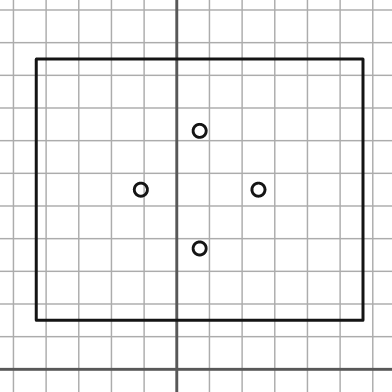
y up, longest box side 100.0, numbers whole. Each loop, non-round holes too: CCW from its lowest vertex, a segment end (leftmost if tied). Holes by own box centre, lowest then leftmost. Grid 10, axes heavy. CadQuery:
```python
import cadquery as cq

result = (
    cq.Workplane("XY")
    .moveTo(-43.0, 15.0)
    .lineTo(57.0, 15.0)
    .lineTo(57.0, 95.0)
    .lineTo(-43.0, 95.0)
    .close()
    .moveTo(7.0, 37.0)
    .circle(2.0)
    .moveTo(-11.0, 55.0)
    .circle(2.0)
    .moveTo(25.0, 55.0)
    .circle(2.0)
    .moveTo(7.0, 73.0)
    .circle(2.0)
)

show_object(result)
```